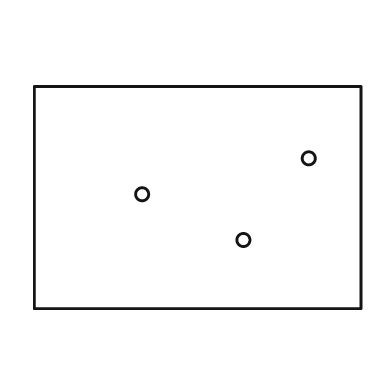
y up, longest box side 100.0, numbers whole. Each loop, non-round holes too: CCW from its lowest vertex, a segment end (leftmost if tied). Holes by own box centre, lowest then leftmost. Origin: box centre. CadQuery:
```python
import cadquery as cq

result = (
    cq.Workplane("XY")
    .moveTo(-50.0, -34.0)
    .lineTo(50.0, -34.0)
    .lineTo(50.0, 34.0)
    .lineTo(-50.0, 34.0)
    .close()
    .moveTo(14.0, -13.0)
    .circle(2.0)
    .moveTo(-17.0, 1.0)
    .circle(2.0)
    .moveTo(34.0, 12.0)
    .circle(2.0)
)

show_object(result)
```